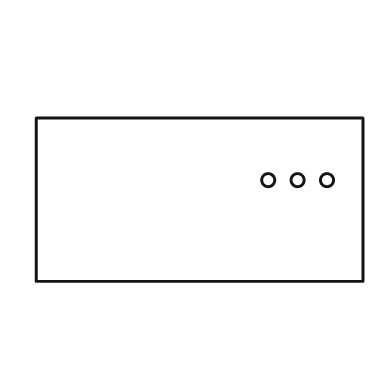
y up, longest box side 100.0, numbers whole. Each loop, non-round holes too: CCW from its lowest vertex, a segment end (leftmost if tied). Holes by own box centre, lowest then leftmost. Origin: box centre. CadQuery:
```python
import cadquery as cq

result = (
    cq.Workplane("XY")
    .moveTo(-50.0, -25.0)
    .lineTo(50.0, -25.0)
    .lineTo(50.0, 25.0)
    .lineTo(-50.0, 25.0)
    .close()
    .moveTo(21.0, 6.0)
    .circle(2.0)
    .moveTo(30.0, 6.0)
    .circle(2.0)
    .moveTo(39.0, 6.0)
    .circle(2.0)
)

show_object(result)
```